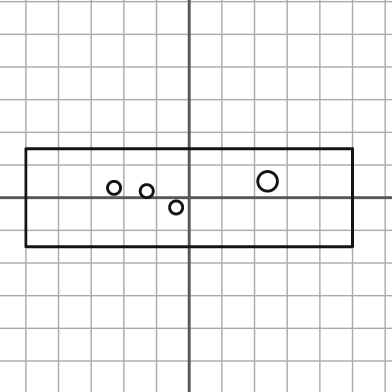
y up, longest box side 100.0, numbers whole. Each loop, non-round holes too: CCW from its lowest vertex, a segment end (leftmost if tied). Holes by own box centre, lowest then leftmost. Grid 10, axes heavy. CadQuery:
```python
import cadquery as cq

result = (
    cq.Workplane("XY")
    .moveTo(-50.0, -15.0)
    .lineTo(50.0, -15.0)
    .lineTo(50.0, 15.0)
    .lineTo(-50.0, 15.0)
    .close()
    .moveTo(-4.0, -3.0)
    .circle(2.0)
    .moveTo(-13.0, 2.0)
    .circle(2.0)
    .moveTo(-23.0, 3.0)
    .circle(2.0)
    .moveTo(24.0, 5.0)
    .circle(3.0)
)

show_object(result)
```